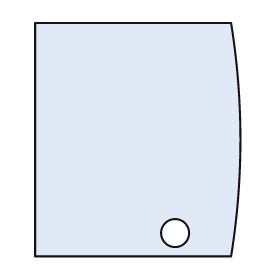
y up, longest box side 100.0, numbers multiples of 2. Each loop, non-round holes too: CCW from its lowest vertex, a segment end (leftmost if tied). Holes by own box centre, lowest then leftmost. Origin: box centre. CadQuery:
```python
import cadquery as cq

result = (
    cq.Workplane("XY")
    .moveTo(-44.0, -50.0)
    .lineTo(40.0, -50.0)
    .threePointArc((44.0, 0.0), (40.0, 50.0))
    .lineTo(-44.0, 50.0)
    .close()
    .moveTo(16.0, -40.0)
    .circle(6.0)
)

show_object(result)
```